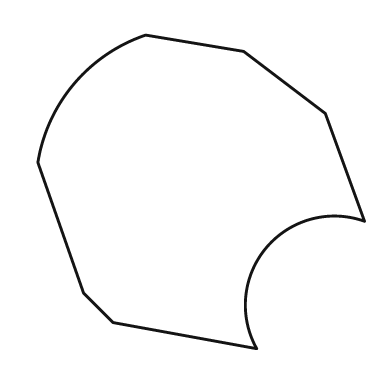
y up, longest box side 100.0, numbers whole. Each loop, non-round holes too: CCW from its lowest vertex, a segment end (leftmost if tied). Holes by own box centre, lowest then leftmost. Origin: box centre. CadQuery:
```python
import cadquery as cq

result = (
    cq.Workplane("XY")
    .moveTo(17.0, -48.0)
    .threePointArc((20.0, -17.0), (50.0, -9.0))
    .lineTo(38.0, 24.0)
    .lineTo(13.0, 43.0)
    .lineTo(-17.0, 48.0)
    .threePointArc((-39.0, 33.0), (-50.0, 9.0))
    .lineTo(-36.0, -31.0)
    .lineTo(-27.0, -40.0)
    .close()
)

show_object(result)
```